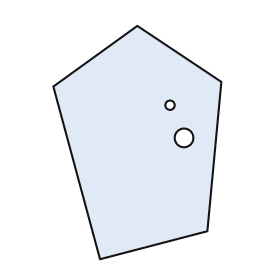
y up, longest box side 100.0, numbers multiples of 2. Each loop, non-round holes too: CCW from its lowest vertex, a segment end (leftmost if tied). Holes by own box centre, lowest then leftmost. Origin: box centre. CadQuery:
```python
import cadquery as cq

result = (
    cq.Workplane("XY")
    .moveTo(-16.0, -50.0)
    .lineTo(30.0, -38.0)
    .lineTo(36.0, 26.0)
    .lineTo(0.0, 50.0)
    .lineTo(-36.0, 24.0)
    .close()
    .moveTo(20.0, 2.0)
    .circle(4.0)
    .moveTo(14.0, 16.0)
    .circle(2.0)
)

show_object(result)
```